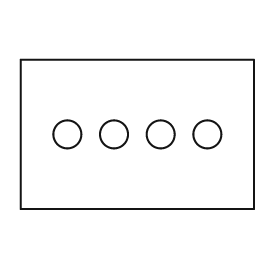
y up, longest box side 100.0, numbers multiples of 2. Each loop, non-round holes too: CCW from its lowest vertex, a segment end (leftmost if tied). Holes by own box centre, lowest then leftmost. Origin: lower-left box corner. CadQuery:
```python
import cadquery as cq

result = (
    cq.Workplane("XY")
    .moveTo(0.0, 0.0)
    .lineTo(100.0, 0.0)
    .lineTo(100.0, 64.0)
    .lineTo(0.0, 64.0)
    .close()
    .moveTo(20.0, 32.0)
    .circle(6.0)
    .moveTo(40.0, 32.0)
    .circle(6.0)
    .moveTo(60.0, 32.0)
    .circle(6.0)
    .moveTo(80.0, 32.0)
    .circle(6.0)
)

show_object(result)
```